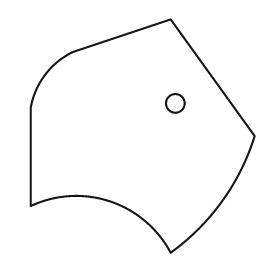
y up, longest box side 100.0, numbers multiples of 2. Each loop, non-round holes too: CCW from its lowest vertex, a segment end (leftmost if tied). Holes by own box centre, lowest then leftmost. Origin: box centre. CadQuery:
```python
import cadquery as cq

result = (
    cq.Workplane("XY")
    .moveTo(12.0, -50.0)
    .threePointArc((34.0, -28.0), (48.0, 0.0))
    .lineTo(12.0, 50.0)
    .lineTo(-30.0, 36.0)
    .threePointArc((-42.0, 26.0), (-48.0, 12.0))
    .lineTo(-48.0, -30.0)
    .threePointArc((-14.0, -28.0), (12.0, -50.0))
    .close()
    .moveTo(14.0, 14.0)
    .circle(4.0)
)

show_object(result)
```